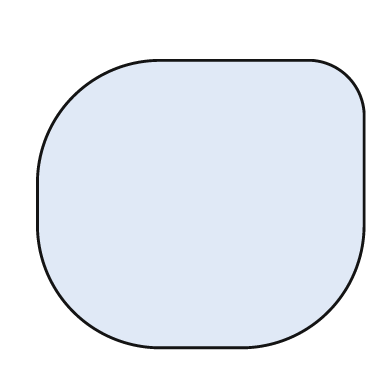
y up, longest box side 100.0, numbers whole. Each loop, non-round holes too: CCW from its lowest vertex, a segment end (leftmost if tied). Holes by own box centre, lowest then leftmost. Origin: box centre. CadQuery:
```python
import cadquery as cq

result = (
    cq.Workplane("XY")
    .moveTo(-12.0, -44.0)
    .lineTo(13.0, -44.0)
    .threePointArc((39.0, -33.0), (50.0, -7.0))
    .lineTo(50.0, 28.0)
    .threePointArc((45.0, 39.0), (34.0, 44.0))
    .lineTo(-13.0, 44.0)
    .threePointArc((-39.0, 33.0), (-50.0, 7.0))
    .lineTo(-50.0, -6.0)
    .threePointArc((-39.0, -33.0), (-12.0, -44.0))
    .close()
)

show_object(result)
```